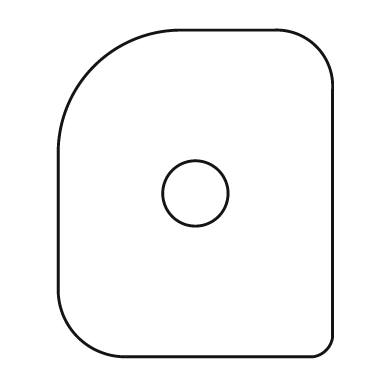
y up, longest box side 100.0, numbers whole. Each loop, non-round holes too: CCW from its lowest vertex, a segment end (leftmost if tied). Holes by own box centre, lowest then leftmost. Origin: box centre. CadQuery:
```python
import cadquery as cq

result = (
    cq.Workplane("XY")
    .moveTo(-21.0, -50.0)
    .lineTo(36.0, -50.0)
    .threePointArc((40.0, -48.0), (42.0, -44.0))
    .lineTo(42.0, 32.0)
    .threePointArc((37.0, 45.0), (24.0, 50.0))
    .lineTo(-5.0, 50.0)
    .threePointArc((-31.0, 39.0), (-42.0, 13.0))
    .lineTo(-42.0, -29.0)
    .threePointArc((-36.0, -44.0), (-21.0, -50.0))
    .close()
    .moveTo(0.0, 0.0)
    .circle(10.0)
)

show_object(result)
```